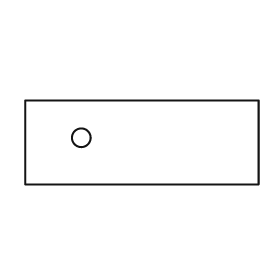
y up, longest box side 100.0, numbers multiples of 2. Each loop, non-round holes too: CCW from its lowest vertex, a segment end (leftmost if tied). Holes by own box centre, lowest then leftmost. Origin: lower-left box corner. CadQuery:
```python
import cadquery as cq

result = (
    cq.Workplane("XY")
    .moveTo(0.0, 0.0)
    .lineTo(100.0, 0.0)
    .lineTo(100.0, 36.0)
    .lineTo(0.0, 36.0)
    .close()
    .moveTo(24.0, 20.0)
    .circle(4.0)
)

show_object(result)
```